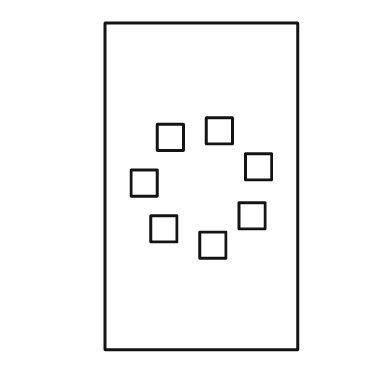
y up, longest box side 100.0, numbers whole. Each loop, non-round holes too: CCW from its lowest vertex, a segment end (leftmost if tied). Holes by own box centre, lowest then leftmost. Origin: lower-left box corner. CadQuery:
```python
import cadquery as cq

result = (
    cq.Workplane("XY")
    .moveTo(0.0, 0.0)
    .lineTo(59.0, 0.0)
    .lineTo(59.0, 100.0)
    .lineTo(0.0, 100.0)
    .close()
    .moveTo(29.0, 28.0)
    .lineTo(37.0, 28.0)
    .lineTo(37.0, 36.0)
    .lineTo(29.0, 36.0)
    .close()
    .moveTo(14.0, 33.0)
    .lineTo(22.0, 33.0)
    .lineTo(22.0, 41.0)
    .lineTo(14.0, 41.0)
    .close()
    .moveTo(41.0, 37.0)
    .lineTo(49.0, 37.0)
    .lineTo(49.0, 45.0)
    .lineTo(41.0, 45.0)
    .close()
    .moveTo(8.0, 47.0)
    .lineTo(16.0, 47.0)
    .lineTo(16.0, 55.0)
    .lineTo(8.0, 55.0)
    .close()
    .moveTo(43.0, 52.0)
    .lineTo(51.0, 52.0)
    .lineTo(51.0, 60.0)
    .lineTo(43.0, 60.0)
    .close()
    .moveTo(16.0, 61.0)
    .lineTo(24.0, 61.0)
    .lineTo(24.0, 69.0)
    .lineTo(16.0, 69.0)
    .close()
    .moveTo(31.0, 63.0)
    .lineTo(39.0, 63.0)
    .lineTo(39.0, 71.0)
    .lineTo(31.0, 71.0)
    .close()
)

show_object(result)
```